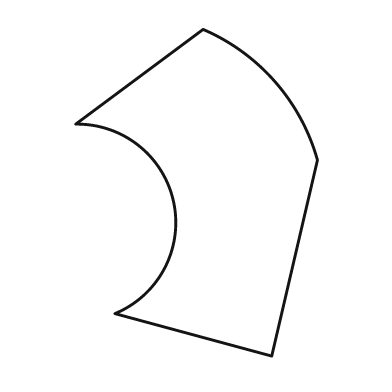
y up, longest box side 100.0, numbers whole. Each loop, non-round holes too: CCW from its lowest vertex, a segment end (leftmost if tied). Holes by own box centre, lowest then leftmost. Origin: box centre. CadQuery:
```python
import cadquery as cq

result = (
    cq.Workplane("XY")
    .moveTo(23.0, -50.0)
    .lineTo(37.0, 10.0)
    .threePointArc((24.0, 34.0), (2.0, 50.0))
    .lineTo(-37.0, 21.0)
    .threePointArc((-7.0, -3.0), (-25.0, -37.0))
    .close()
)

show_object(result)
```